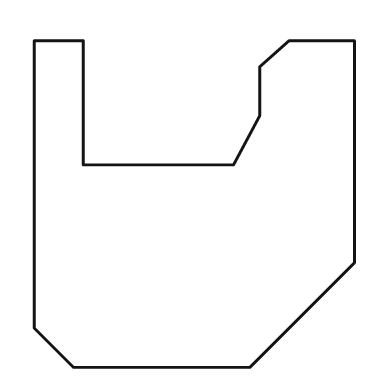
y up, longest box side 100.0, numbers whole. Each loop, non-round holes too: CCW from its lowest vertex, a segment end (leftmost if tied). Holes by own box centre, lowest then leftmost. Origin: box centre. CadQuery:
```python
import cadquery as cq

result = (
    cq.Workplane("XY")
    .moveTo(-37.0, -50.0)
    .lineTo(17.0, -50.0)
    .lineTo(49.0, -18.0)
    .lineTo(49.0, 50.0)
    .lineTo(29.0, 50.0)
    .lineTo(20.0, 42.0)
    .lineTo(20.0, 27.0)
    .lineTo(12.0, 12.0)
    .lineTo(-34.0, 12.0)
    .lineTo(-34.0, 50.0)
    .lineTo(-49.0, 50.0)
    .lineTo(-49.0, -38.0)
    .close()
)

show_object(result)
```